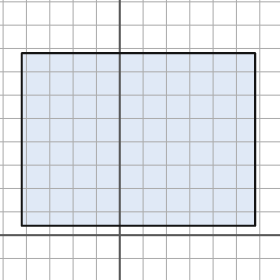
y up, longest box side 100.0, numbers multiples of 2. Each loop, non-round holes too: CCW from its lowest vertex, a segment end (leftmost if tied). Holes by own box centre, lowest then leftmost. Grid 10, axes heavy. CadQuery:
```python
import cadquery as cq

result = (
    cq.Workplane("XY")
    .moveTo(-42.0, 4.0)
    .lineTo(58.0, 4.0)
    .lineTo(58.0, 78.0)
    .lineTo(-42.0, 78.0)
    .close()
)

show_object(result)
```